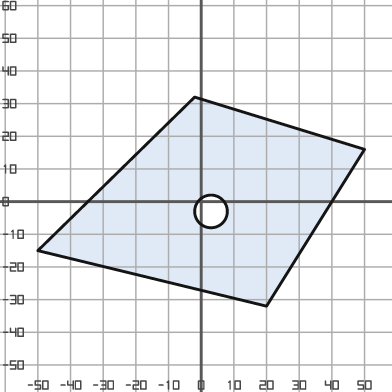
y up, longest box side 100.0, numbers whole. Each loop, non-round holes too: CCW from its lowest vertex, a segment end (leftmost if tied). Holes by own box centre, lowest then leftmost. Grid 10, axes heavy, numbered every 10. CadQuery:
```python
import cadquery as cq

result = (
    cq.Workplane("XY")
    .moveTo(20.0, -32.0)
    .lineTo(50.0, 16.0)
    .lineTo(-2.0, 32.0)
    .lineTo(-50.0, -15.0)
    .close()
    .moveTo(3.0, -3.0)
    .circle(5.0)
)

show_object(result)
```